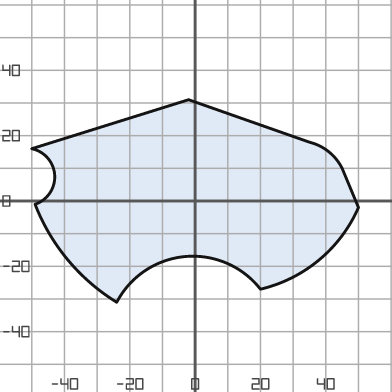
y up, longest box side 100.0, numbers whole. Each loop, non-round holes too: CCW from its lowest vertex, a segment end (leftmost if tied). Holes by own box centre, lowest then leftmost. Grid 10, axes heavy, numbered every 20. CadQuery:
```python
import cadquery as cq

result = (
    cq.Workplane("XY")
    .moveTo(-24.0, -31.0)
    .threePointArc((-3.0, -17.0), (20.0, -27.0))
    .threePointArc((38.0, -18.0), (50.0, -2.0))
    .lineTo(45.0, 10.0)
    .threePointArc((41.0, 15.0), (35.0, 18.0))
    .lineTo(-2.0, 31.0)
    .lineTo(-50.0, 16.0)
    .threePointArc((-43.0, 8.0), (-49.0, -1.0))
    .threePointArc((-39.0, -18.0), (-24.0, -31.0))
    .close()
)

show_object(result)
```